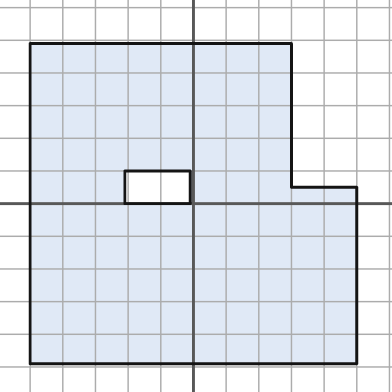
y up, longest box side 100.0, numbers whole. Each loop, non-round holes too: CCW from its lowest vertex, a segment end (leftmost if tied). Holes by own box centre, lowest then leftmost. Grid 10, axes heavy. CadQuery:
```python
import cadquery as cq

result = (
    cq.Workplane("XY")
    .moveTo(-50.0, -49.0)
    .lineTo(50.0, -49.0)
    .lineTo(50.0, 5.0)
    .lineTo(30.0, 5.0)
    .lineTo(30.0, 49.0)
    .lineTo(-50.0, 49.0)
    .close()
    .moveTo(-21.0, 0.0)
    .lineTo(-1.0, 0.0)
    .lineTo(-1.0, 10.0)
    .lineTo(-21.0, 10.0)
    .close()
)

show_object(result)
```